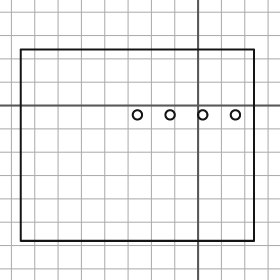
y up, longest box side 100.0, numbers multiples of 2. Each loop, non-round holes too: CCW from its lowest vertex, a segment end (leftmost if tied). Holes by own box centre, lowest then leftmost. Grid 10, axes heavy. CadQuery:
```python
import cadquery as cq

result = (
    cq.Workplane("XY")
    .moveTo(-76.0, -58.0)
    .lineTo(24.0, -58.0)
    .lineTo(24.0, 24.0)
    .lineTo(-76.0, 24.0)
    .close()
    .moveTo(-26.0, -4.0)
    .circle(2.0)
    .moveTo(-12.0, -4.0)
    .circle(2.0)
    .moveTo(2.0, -4.0)
    .circle(2.0)
    .moveTo(16.0, -4.0)
    .circle(2.0)
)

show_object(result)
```